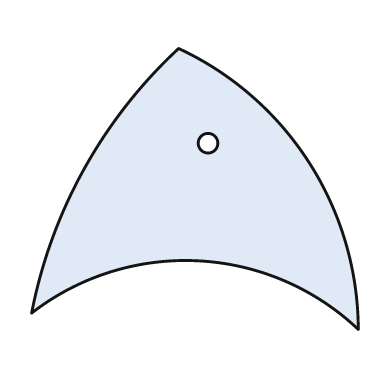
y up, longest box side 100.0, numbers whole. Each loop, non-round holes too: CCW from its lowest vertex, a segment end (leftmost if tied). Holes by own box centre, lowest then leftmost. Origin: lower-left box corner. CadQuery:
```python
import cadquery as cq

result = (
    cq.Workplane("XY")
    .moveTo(100.0, 0.0)
    .threePointArc((85.0, 51.0), (45.0, 86.0))
    .threePointArc((16.0, 49.0), (0.0, 5.0))
    .threePointArc((51.0, 21.0), (100.0, 0.0))
    .close()
    .moveTo(54.0, 57.0)
    .circle(3.0)
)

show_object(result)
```